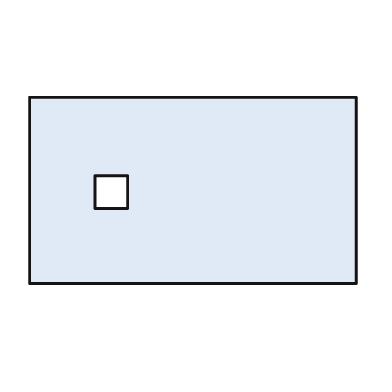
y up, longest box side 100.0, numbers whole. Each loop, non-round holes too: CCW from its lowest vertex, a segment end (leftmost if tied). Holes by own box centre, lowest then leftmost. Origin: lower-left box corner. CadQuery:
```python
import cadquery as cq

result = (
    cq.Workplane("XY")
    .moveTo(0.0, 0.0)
    .lineTo(100.0, 0.0)
    .lineTo(100.0, 57.0)
    .lineTo(0.0, 57.0)
    .close()
    .moveTo(20.0, 23.0)
    .lineTo(30.0, 23.0)
    .lineTo(30.0, 33.0)
    .lineTo(20.0, 33.0)
    .close()
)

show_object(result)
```